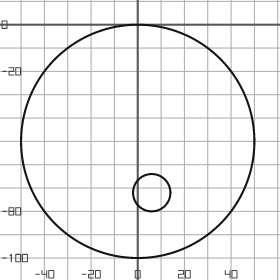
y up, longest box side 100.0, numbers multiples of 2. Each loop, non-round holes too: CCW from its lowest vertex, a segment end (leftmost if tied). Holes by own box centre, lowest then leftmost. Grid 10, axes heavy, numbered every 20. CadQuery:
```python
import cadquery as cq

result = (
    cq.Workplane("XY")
    .moveTo(0.0, -50.0)
    .circle(50.0)
    .moveTo(6.0, -72.0)
    .circle(8.0)
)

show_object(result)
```